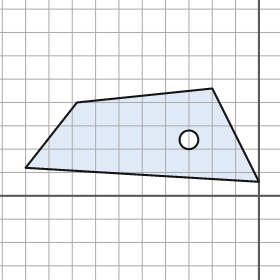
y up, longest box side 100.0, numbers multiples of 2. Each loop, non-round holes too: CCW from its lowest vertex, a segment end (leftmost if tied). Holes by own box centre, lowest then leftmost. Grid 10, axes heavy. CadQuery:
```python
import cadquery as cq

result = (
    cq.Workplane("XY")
    .moveTo(0.0, 6.0)
    .lineTo(-20.0, 46.0)
    .lineTo(-78.0, 40.0)
    .lineTo(-100.0, 12.0)
    .close()
    .moveTo(-30.0, 24.0)
    .circle(4.0)
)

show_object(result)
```